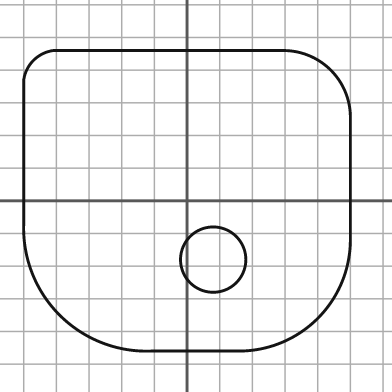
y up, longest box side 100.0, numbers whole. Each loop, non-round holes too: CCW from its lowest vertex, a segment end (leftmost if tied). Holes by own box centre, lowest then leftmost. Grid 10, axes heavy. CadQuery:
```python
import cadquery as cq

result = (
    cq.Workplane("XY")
    .moveTo(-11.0, -46.0)
    .lineTo(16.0, -46.0)
    .threePointArc((40.0, -36.0), (50.0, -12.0))
    .lineTo(50.0, 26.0)
    .threePointArc((44.0, 40.0), (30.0, 46.0))
    .lineTo(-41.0, 46.0)
    .threePointArc((-47.0, 43.0), (-50.0, 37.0))
    .lineTo(-50.0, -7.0)
    .threePointArc((-39.0, -35.0), (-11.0, -46.0))
    .close()
    .moveTo(8.0, -18.0)
    .circle(10.0)
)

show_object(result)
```